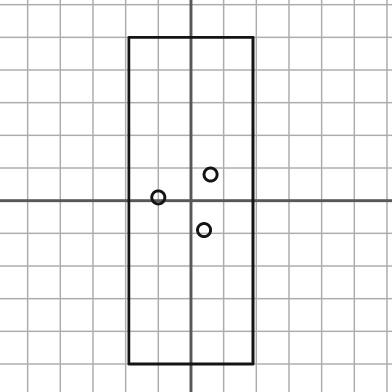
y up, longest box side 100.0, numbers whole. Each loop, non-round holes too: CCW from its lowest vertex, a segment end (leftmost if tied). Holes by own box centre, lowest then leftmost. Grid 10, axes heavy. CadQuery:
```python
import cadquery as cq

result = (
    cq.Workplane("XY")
    .moveTo(-19.0, -50.0)
    .lineTo(19.0, -50.0)
    .lineTo(19.0, 50.0)
    .lineTo(-19.0, 50.0)
    .close()
    .moveTo(4.0, -9.0)
    .circle(2.0)
    .moveTo(-10.0, 1.0)
    .circle(2.0)
    .moveTo(6.0, 8.0)
    .circle(2.0)
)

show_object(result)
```